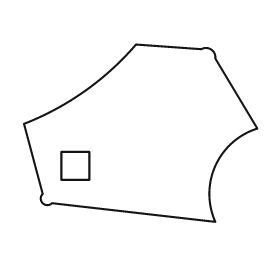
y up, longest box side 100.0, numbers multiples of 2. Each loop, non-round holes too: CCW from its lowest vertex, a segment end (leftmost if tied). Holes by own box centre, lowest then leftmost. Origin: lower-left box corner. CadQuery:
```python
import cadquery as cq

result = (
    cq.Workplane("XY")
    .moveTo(82.0, 0.0)
    .threePointArc((82.0, 24.0), (100.0, 40.0))
    .lineTo(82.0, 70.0)
    .threePointArc((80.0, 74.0), (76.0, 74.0))
    .lineTo(48.0, 76.0)
    .threePointArc((26.0, 56.0), (0.0, 42.0))
    .lineTo(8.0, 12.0)
    .threePointArc((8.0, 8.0), (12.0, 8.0))
    .close()
    .moveTo(16.0, 18.0)
    .lineTo(28.0, 18.0)
    .lineTo(28.0, 30.0)
    .lineTo(16.0, 30.0)
    .close()
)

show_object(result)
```